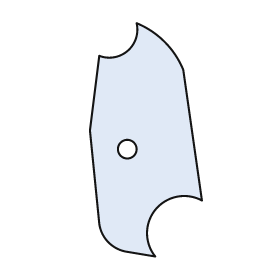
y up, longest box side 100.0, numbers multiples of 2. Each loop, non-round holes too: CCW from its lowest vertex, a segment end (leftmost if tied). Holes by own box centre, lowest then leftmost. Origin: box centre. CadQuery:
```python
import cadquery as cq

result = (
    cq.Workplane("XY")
    .moveTo(4.0, -50.0)
    .threePointArc((4.0, -30.0), (24.0, -26.0))
    .lineTo(16.0, 30.0)
    .threePointArc((8.0, 42.0), (-4.0, 50.0))
    .threePointArc((-8.0, 38.0), (-20.0, 36.0))
    .lineTo(-24.0, 4.0)
    .lineTo(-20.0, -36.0)
    .threePointArc((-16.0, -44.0), (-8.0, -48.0))
    .close()
    .moveTo(-8.0, -4.0)
    .circle(4.0)
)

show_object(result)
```